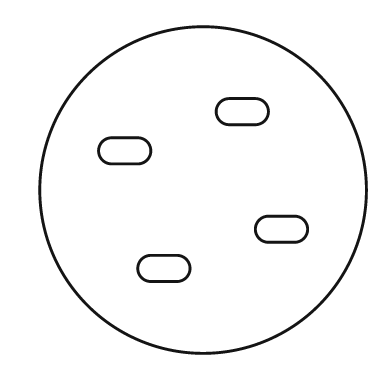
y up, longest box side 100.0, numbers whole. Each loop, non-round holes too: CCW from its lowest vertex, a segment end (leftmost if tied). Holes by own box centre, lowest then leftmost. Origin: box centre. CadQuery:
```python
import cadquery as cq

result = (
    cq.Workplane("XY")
    .moveTo(0.0, 0.0)
    .circle(50.0)
    .moveTo(-16.0, -28.0)
    .lineTo(-8.0, -28.0)
    .threePointArc((-4.0, -24.0), (-8.0, -20.0))
    .lineTo(-16.0, -20.0)
    .threePointArc((-20.0, -24.0), (-16.0, -28.0))
    .close()
    .moveTo(20.0, -16.0)
    .lineTo(28.0, -16.0)
    .threePointArc((32.0, -12.0), (28.0, -8.0))
    .lineTo(20.0, -8.0)
    .threePointArc((16.0, -12.0), (20.0, -16.0))
    .close()
    .moveTo(-28.0, 8.0)
    .lineTo(-20.0, 8.0)
    .threePointArc((-16.0, 12.0), (-20.0, 16.0))
    .lineTo(-28.0, 16.0)
    .threePointArc((-32.0, 12.0), (-28.0, 8.0))
    .close()
    .moveTo(8.0, 20.0)
    .lineTo(16.0, 20.0)
    .threePointArc((20.0, 24.0), (16.0, 28.0))
    .lineTo(8.0, 28.0)
    .threePointArc((4.0, 24.0), (8.0, 20.0))
    .close()
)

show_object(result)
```